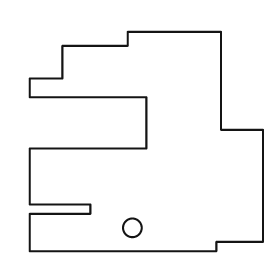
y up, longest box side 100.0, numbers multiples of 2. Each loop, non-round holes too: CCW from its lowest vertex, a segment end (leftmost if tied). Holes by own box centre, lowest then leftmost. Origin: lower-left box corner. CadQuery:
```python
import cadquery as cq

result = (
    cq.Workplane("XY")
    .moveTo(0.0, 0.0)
    .lineTo(80.0, 0.0)
    .lineTo(80.0, 4.0)
    .lineTo(100.0, 4.0)
    .lineTo(100.0, 52.0)
    .lineTo(82.0, 52.0)
    .lineTo(82.0, 94.0)
    .lineTo(42.0, 94.0)
    .lineTo(42.0, 88.0)
    .lineTo(14.0, 88.0)
    .lineTo(14.0, 74.0)
    .lineTo(0.0, 74.0)
    .lineTo(0.0, 66.0)
    .lineTo(50.0, 66.0)
    .lineTo(50.0, 44.0)
    .lineTo(0.0, 44.0)
    .lineTo(0.0, 20.0)
    .lineTo(26.0, 20.0)
    .lineTo(26.0, 16.0)
    .lineTo(0.0, 16.0)
    .close()
    .moveTo(44.0, 10.0)
    .circle(4.0)
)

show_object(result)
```